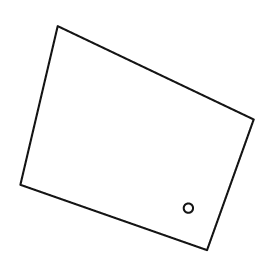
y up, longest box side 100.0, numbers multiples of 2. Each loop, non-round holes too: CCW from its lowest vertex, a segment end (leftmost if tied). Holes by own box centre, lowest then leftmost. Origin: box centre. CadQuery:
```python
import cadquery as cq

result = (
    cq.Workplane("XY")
    .moveTo(30.0, -48.0)
    .lineTo(50.0, 8.0)
    .lineTo(-34.0, 48.0)
    .lineTo(-50.0, -20.0)
    .close()
    .moveTo(22.0, -30.0)
    .circle(2.0)
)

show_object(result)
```